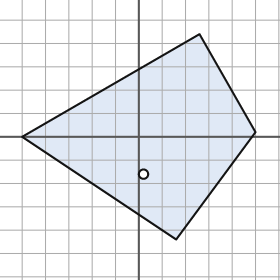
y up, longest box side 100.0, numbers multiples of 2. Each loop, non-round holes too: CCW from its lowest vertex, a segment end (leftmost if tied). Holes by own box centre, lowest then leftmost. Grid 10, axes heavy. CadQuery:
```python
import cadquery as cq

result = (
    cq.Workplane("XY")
    .moveTo(16.0, -44.0)
    .lineTo(50.0, 2.0)
    .lineTo(26.0, 44.0)
    .lineTo(-50.0, 0.0)
    .close()
    .moveTo(2.0, -16.0)
    .circle(2.0)
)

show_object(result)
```